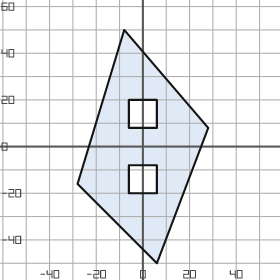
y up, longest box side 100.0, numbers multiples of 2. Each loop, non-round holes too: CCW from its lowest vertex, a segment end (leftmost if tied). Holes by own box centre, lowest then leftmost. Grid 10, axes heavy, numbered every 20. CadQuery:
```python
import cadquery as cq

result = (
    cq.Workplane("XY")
    .moveTo(6.0, -50.0)
    .lineTo(28.0, 8.0)
    .lineTo(-8.0, 50.0)
    .lineTo(-28.0, -16.0)
    .close()
    .moveTo(-6.0, -20.0)
    .lineTo(6.0, -20.0)
    .lineTo(6.0, -8.0)
    .lineTo(-6.0, -8.0)
    .close()
    .moveTo(-6.0, 8.0)
    .lineTo(6.0, 8.0)
    .lineTo(6.0, 20.0)
    .lineTo(-6.0, 20.0)
    .close()
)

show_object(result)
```